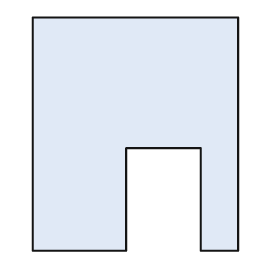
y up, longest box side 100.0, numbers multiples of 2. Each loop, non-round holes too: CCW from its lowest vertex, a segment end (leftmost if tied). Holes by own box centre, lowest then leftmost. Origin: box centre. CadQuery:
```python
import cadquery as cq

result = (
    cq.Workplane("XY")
    .moveTo(-44.0, -50.0)
    .lineTo(-4.0, -50.0)
    .lineTo(-4.0, -6.0)
    .lineTo(28.0, -6.0)
    .lineTo(28.0, -50.0)
    .lineTo(44.0, -50.0)
    .lineTo(44.0, 50.0)
    .lineTo(-44.0, 50.0)
    .close()
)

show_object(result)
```